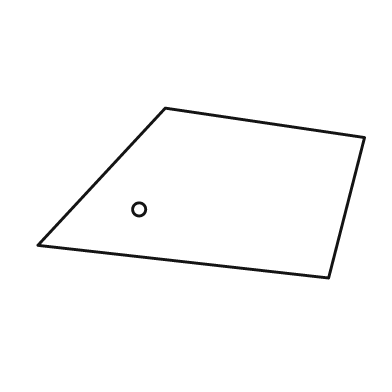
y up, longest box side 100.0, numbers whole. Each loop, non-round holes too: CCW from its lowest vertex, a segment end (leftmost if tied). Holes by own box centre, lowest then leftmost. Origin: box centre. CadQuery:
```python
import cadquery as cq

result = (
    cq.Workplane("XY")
    .moveTo(39.0, -26.0)
    .lineTo(50.0, 17.0)
    .lineTo(-11.0, 26.0)
    .lineTo(-50.0, -16.0)
    .close()
    .moveTo(-19.0, -5.0)
    .circle(2.0)
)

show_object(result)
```